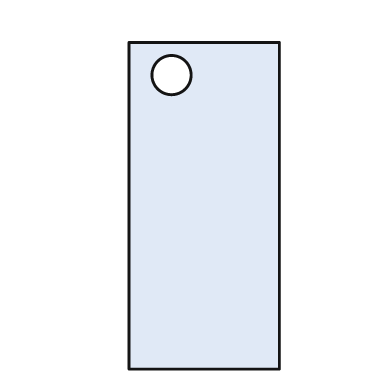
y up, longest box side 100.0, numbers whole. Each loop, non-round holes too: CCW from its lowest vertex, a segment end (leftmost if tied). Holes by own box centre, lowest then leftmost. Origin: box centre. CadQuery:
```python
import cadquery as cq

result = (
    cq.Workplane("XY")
    .moveTo(-23.0, -50.0)
    .lineTo(23.0, -50.0)
    .lineTo(23.0, 50.0)
    .lineTo(-23.0, 50.0)
    .close()
    .moveTo(-10.0, 40.0)
    .circle(6.0)
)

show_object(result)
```